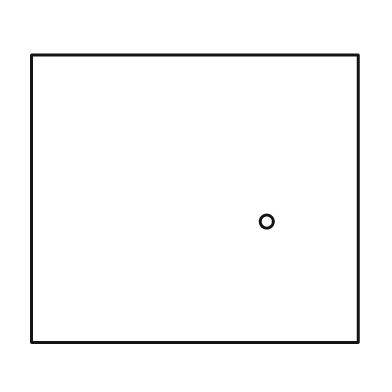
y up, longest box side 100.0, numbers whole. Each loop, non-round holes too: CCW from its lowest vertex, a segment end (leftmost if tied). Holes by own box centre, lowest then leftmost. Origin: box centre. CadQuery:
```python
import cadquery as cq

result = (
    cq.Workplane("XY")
    .moveTo(-50.0, -44.0)
    .lineTo(50.0, -44.0)
    .lineTo(50.0, 44.0)
    .lineTo(-50.0, 44.0)
    .close()
    .moveTo(22.0, -7.0)
    .circle(2.0)
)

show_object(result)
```